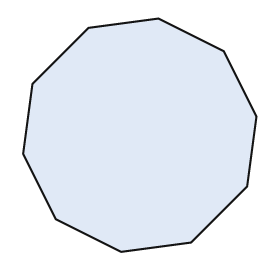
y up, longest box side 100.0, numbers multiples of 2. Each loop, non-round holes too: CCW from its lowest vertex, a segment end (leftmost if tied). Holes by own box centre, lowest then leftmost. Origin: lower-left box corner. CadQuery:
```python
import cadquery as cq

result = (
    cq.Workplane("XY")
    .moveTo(42.0, 0.0)
    .lineTo(72.0, 4.0)
    .lineTo(96.0, 28.0)
    .lineTo(100.0, 58.0)
    .lineTo(86.0, 86.0)
    .lineTo(58.0, 100.0)
    .lineTo(28.0, 96.0)
    .lineTo(4.0, 72.0)
    .lineTo(0.0, 42.0)
    .lineTo(14.0, 14.0)
    .close()
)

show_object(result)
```